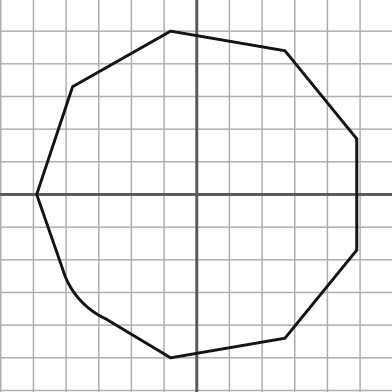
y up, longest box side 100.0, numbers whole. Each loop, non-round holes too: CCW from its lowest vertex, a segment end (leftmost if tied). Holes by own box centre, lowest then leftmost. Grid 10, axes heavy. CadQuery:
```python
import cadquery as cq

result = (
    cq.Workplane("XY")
    .moveTo(-8.0, -50.0)
    .lineTo(27.0, -44.0)
    .lineTo(49.0, -17.0)
    .lineTo(49.0, 17.0)
    .lineTo(27.0, 44.0)
    .lineTo(-8.0, 50.0)
    .lineTo(-38.0, 33.0)
    .lineTo(-49.0, 0.0)
    .lineTo(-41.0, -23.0)
    .threePointArc((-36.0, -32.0), (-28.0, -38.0))
    .close()
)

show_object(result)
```